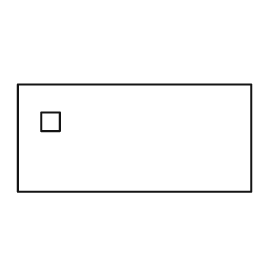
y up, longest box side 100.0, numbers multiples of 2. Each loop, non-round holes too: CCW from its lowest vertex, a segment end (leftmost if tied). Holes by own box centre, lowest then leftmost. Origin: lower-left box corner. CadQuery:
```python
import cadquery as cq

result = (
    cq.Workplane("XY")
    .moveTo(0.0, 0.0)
    .lineTo(100.0, 0.0)
    .lineTo(100.0, 46.0)
    .lineTo(0.0, 46.0)
    .close()
    .moveTo(10.0, 26.0)
    .lineTo(18.0, 26.0)
    .lineTo(18.0, 34.0)
    .lineTo(10.0, 34.0)
    .close()
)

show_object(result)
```